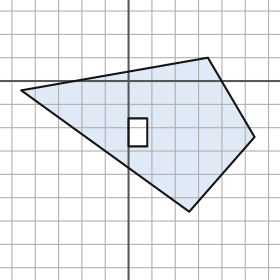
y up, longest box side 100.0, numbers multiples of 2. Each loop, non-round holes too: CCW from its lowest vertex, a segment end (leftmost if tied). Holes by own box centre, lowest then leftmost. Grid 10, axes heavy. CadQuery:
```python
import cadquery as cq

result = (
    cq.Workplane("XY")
    .moveTo(26.0, -56.0)
    .lineTo(54.0, -24.0)
    .lineTo(34.0, 10.0)
    .lineTo(-46.0, -4.0)
    .close()
    .moveTo(0.0, -28.0)
    .lineTo(8.0, -28.0)
    .lineTo(8.0, -16.0)
    .lineTo(0.0, -16.0)
    .close()
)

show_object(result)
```